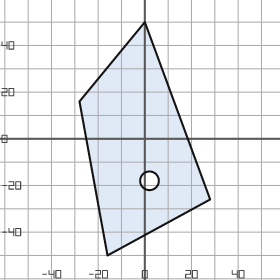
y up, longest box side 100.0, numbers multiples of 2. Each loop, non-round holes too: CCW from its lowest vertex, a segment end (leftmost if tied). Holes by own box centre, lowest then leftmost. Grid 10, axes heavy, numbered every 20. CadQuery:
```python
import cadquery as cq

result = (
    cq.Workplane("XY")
    .moveTo(-16.0, -50.0)
    .lineTo(28.0, -26.0)
    .lineTo(0.0, 50.0)
    .lineTo(-28.0, 16.0)
    .close()
    .moveTo(2.0, -18.0)
    .circle(4.0)
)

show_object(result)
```